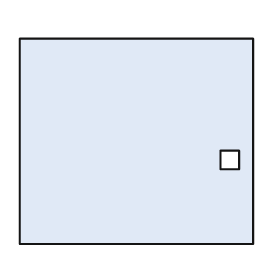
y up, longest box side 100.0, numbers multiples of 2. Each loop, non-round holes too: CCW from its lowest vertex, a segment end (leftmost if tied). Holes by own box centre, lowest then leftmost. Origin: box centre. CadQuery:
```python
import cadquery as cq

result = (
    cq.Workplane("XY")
    .moveTo(-50.0, -44.0)
    .lineTo(50.0, -44.0)
    .lineTo(50.0, 44.0)
    .lineTo(-50.0, 44.0)
    .close()
    .moveTo(36.0, -12.0)
    .lineTo(44.0, -12.0)
    .lineTo(44.0, -4.0)
    .lineTo(36.0, -4.0)
    .close()
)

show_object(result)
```